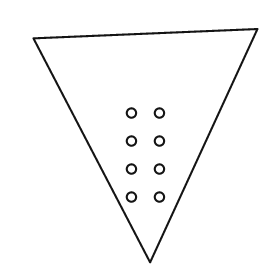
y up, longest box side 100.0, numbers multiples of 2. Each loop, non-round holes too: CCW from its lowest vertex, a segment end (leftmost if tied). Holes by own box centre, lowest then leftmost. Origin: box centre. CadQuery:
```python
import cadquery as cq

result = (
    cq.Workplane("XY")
    .moveTo(2.0, -50.0)
    .lineTo(48.0, 50.0)
    .lineTo(-48.0, 46.0)
    .close()
    .moveTo(-6.0, -22.0)
    .circle(2.0)
    .moveTo(6.0, -22.0)
    .circle(2.0)
    .moveTo(-6.0, -10.0)
    .circle(2.0)
    .moveTo(6.0, -10.0)
    .circle(2.0)
    .moveTo(-6.0, 2.0)
    .circle(2.0)
    .moveTo(6.0, 2.0)
    .circle(2.0)
    .moveTo(-6.0, 14.0)
    .circle(2.0)
    .moveTo(6.0, 14.0)
    .circle(2.0)
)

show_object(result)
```